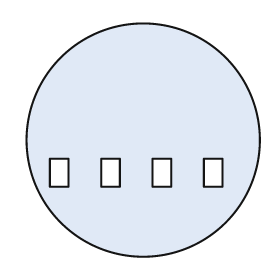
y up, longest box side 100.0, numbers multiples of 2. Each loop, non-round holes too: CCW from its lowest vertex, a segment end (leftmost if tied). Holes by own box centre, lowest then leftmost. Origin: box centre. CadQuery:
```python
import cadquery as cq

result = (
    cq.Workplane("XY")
    .moveTo(0.0, 0.0)
    .circle(50.0)
    .moveTo(-40.0, -20.0)
    .lineTo(-32.0, -20.0)
    .lineTo(-32.0, -8.0)
    .lineTo(-40.0, -8.0)
    .close()
    .moveTo(-18.0, -20.0)
    .lineTo(-10.0, -20.0)
    .lineTo(-10.0, -8.0)
    .lineTo(-18.0, -8.0)
    .close()
    .moveTo(4.0, -20.0)
    .lineTo(12.0, -20.0)
    .lineTo(12.0, -8.0)
    .lineTo(4.0, -8.0)
    .close()
    .moveTo(26.0, -20.0)
    .lineTo(34.0, -20.0)
    .lineTo(34.0, -8.0)
    .lineTo(26.0, -8.0)
    .close()
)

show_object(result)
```